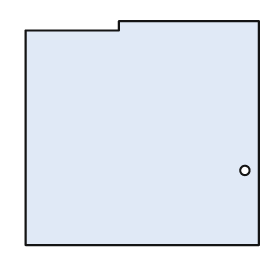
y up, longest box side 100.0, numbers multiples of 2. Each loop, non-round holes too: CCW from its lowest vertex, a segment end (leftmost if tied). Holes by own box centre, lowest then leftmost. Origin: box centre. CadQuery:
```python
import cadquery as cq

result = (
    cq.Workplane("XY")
    .moveTo(-50.0, -48.0)
    .lineTo(50.0, -48.0)
    .lineTo(50.0, 48.0)
    .lineTo(-10.0, 48.0)
    .lineTo(-10.0, 44.0)
    .lineTo(-50.0, 44.0)
    .close()
    .moveTo(44.0, -16.0)
    .circle(2.0)
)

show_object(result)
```